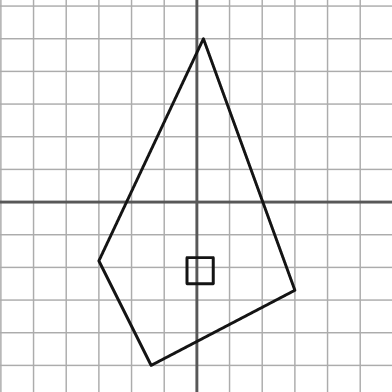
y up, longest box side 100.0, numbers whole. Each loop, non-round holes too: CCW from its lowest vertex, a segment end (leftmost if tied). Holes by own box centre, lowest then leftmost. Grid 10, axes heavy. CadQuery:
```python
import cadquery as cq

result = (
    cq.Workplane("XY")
    .moveTo(-14.0, -50.0)
    .lineTo(30.0, -27.0)
    .lineTo(2.0, 50.0)
    .lineTo(-30.0, -18.0)
    .close()
    .moveTo(-3.0, -25.0)
    .lineTo(5.0, -25.0)
    .lineTo(5.0, -17.0)
    .lineTo(-3.0, -17.0)
    .close()
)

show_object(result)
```